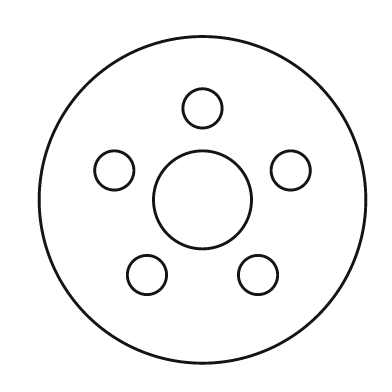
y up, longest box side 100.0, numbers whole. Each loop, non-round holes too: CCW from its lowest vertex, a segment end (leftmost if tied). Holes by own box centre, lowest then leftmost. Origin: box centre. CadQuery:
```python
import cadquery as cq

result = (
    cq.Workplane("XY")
    .moveTo(0.0, 0.0)
    .circle(50.0)
    .moveTo(-17.0, -23.0)
    .circle(6.0)
    .moveTo(17.0, -23.0)
    .circle(6.0)
    .moveTo(0.0, 0.0)
    .circle(15.0)
    .moveTo(-27.0, 9.0)
    .circle(6.0)
    .moveTo(27.0, 9.0)
    .circle(6.0)
    .moveTo(0.0, 28.0)
    .circle(6.0)
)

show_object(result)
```